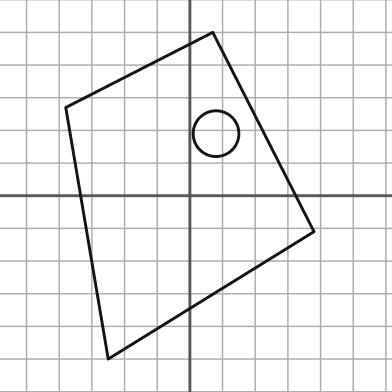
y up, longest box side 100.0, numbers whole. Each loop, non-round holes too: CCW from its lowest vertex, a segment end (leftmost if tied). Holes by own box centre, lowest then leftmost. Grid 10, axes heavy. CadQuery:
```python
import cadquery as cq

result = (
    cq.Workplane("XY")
    .moveTo(-25.0, -50.0)
    .lineTo(38.0, -11.0)
    .lineTo(7.0, 50.0)
    .lineTo(-38.0, 27.0)
    .close()
    .moveTo(8.0, 19.0)
    .circle(7.0)
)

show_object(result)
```